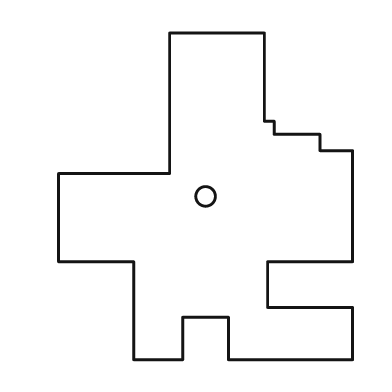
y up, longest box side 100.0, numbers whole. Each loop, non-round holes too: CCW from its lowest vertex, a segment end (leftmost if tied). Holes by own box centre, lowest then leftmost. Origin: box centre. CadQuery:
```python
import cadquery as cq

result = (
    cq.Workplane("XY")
    .moveTo(-22.0, -50.0)
    .lineTo(-7.0, -50.0)
    .lineTo(-7.0, -37.0)
    .lineTo(7.0, -37.0)
    .lineTo(7.0, -50.0)
    .lineTo(45.0, -50.0)
    .lineTo(45.0, -34.0)
    .lineTo(19.0, -34.0)
    .lineTo(19.0, -20.0)
    .lineTo(45.0, -20.0)
    .lineTo(45.0, 14.0)
    .lineTo(35.0, 14.0)
    .lineTo(35.0, 19.0)
    .lineTo(21.0, 19.0)
    .lineTo(21.0, 23.0)
    .lineTo(18.0, 23.0)
    .lineTo(18.0, 50.0)
    .lineTo(-11.0, 50.0)
    .lineTo(-11.0, 7.0)
    .lineTo(-45.0, 7.0)
    .lineTo(-45.0, -20.0)
    .lineTo(-22.0, -20.0)
    .close()
    .moveTo(0.0, 0.0)
    .circle(3.0)
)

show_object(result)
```